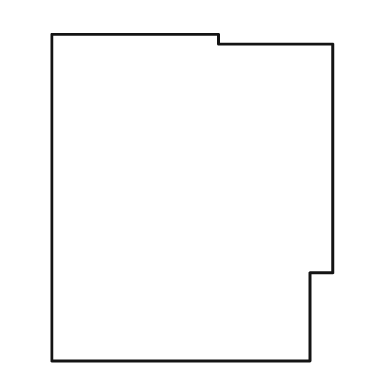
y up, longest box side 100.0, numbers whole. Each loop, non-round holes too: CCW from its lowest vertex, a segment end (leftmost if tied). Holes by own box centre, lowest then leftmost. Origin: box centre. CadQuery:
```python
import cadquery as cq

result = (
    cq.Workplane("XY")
    .moveTo(-43.0, -50.0)
    .lineTo(36.0, -50.0)
    .lineTo(36.0, -23.0)
    .lineTo(43.0, -23.0)
    .lineTo(43.0, 47.0)
    .lineTo(8.0, 47.0)
    .lineTo(8.0, 50.0)
    .lineTo(-43.0, 50.0)
    .close()
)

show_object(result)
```